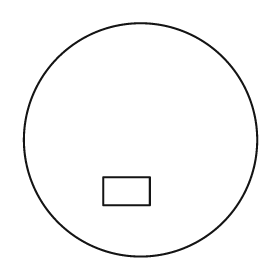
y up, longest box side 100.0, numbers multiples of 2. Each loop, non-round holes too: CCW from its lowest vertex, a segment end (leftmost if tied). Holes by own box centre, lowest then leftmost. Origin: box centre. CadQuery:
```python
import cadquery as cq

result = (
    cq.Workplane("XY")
    .moveTo(0.0, 0.0)
    .circle(50.0)
    .moveTo(-16.0, -28.0)
    .lineTo(4.0, -28.0)
    .lineTo(4.0, -16.0)
    .lineTo(-16.0, -16.0)
    .close()
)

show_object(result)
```